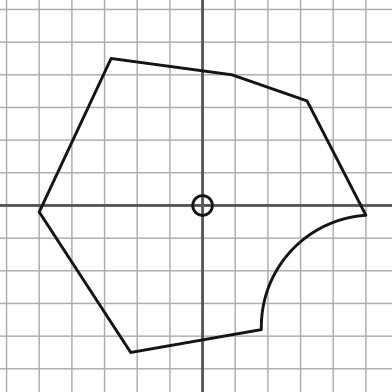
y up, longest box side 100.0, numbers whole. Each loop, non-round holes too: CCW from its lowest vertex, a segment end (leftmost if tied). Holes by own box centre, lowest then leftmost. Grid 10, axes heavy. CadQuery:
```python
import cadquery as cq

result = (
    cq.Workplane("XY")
    .moveTo(-22.0, -45.0)
    .lineTo(18.0, -38.0)
    .threePointArc((27.0, -14.0), (50.0, -3.0))
    .lineTo(32.0, 32.0)
    .lineTo(9.0, 40.0)
    .lineTo(-28.0, 45.0)
    .lineTo(-50.0, -2.0)
    .close()
    .moveTo(0.0, 0.0)
    .circle(3.0)
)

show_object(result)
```